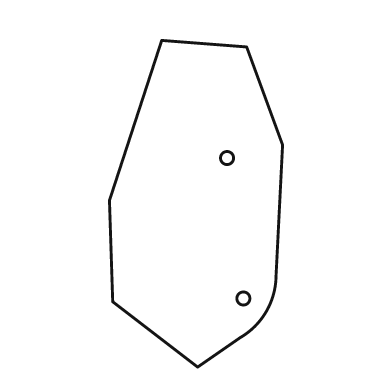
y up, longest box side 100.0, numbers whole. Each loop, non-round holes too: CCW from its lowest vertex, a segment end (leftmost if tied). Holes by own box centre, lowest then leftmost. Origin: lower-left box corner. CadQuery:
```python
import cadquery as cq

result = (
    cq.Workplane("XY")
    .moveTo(27.0, 0.0)
    .lineTo(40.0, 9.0)
    .threePointArc((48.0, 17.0), (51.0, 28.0))
    .lineTo(53.0, 68.0)
    .lineTo(42.0, 98.0)
    .lineTo(16.0, 100.0)
    .lineTo(0.0, 51.0)
    .lineTo(1.0, 20.0)
    .close()
    .moveTo(41.0, 21.0)
    .circle(2.0)
    .moveTo(36.0, 64.0)
    .circle(2.0)
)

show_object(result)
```